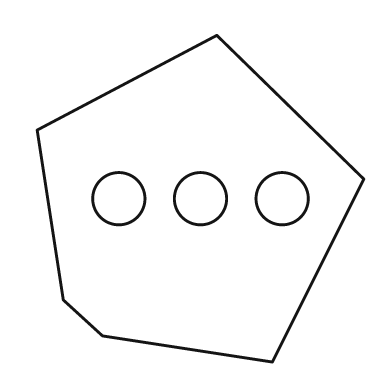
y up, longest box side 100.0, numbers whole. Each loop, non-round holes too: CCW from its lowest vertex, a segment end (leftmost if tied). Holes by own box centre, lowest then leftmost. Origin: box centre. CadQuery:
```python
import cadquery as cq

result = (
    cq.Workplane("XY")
    .moveTo(22.0, -50.0)
    .lineTo(50.0, 6.0)
    .lineTo(5.0, 50.0)
    .lineTo(-50.0, 21.0)
    .lineTo(-42.0, -31.0)
    .lineTo(-30.0, -42.0)
    .close()
    .moveTo(-25.0, 0.0)
    .circle(8.0)
    .moveTo(0.0, 0.0)
    .circle(8.0)
    .moveTo(25.0, 0.0)
    .circle(8.0)
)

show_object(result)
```